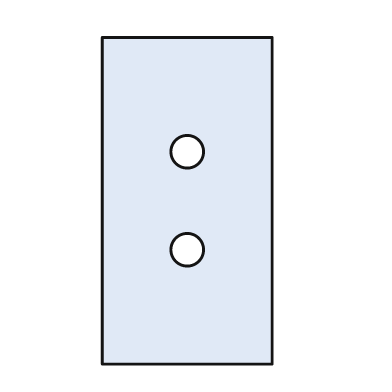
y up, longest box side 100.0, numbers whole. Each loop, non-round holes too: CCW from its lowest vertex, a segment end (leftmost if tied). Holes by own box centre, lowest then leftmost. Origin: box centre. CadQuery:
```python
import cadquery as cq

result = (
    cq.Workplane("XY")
    .moveTo(-26.0, -50.0)
    .lineTo(26.0, -50.0)
    .lineTo(26.0, 50.0)
    .lineTo(-26.0, 50.0)
    .close()
    .moveTo(0.0, -15.0)
    .circle(5.0)
    .moveTo(0.0, 15.0)
    .circle(5.0)
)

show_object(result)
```